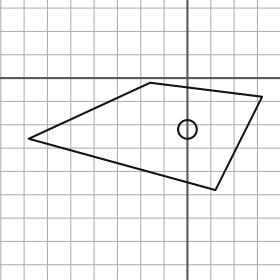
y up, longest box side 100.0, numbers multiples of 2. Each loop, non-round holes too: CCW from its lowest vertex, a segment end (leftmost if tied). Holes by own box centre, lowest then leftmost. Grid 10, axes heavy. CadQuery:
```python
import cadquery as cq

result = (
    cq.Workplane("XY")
    .moveTo(12.0, -48.0)
    .lineTo(32.0, -8.0)
    .lineTo(-16.0, -2.0)
    .lineTo(-68.0, -26.0)
    .close()
    .moveTo(0.0, -22.0)
    .circle(4.0)
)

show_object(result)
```